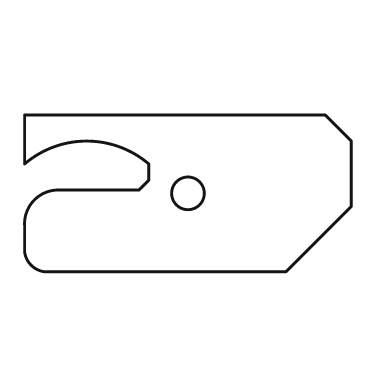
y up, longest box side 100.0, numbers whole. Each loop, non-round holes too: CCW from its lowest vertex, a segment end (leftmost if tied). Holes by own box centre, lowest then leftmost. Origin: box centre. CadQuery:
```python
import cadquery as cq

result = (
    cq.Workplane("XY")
    .moveTo(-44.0, -24.0)
    .lineTo(30.0, -24.0)
    .lineTo(50.0, -4.0)
    .lineTo(50.0, 16.0)
    .lineTo(42.0, 24.0)
    .lineTo(-50.0, 24.0)
    .lineTo(-50.0, 9.0)
    .threePointArc((-31.0, 16.0), (-12.0, 9.0))
    .lineTo(-12.0, 4.0)
    .lineTo(-15.0, 1.0)
    .lineTo(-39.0, 1.0)
    .threePointArc((-47.0, -2.0), (-50.0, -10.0))
    .lineTo(-50.0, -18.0)
    .threePointArc((-48.0, -22.0), (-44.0, -24.0))
    .close()
    .moveTo(0.0, 0.0)
    .circle(5.0)
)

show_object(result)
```